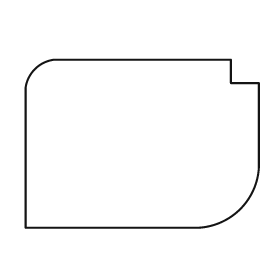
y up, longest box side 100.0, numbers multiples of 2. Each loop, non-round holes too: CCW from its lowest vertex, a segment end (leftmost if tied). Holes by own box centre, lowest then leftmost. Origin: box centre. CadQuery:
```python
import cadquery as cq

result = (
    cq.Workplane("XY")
    .moveTo(-50.0, -36.0)
    .lineTo(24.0, -36.0)
    .threePointArc((42.0, -28.0), (50.0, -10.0))
    .lineTo(50.0, 26.0)
    .lineTo(38.0, 26.0)
    .lineTo(38.0, 36.0)
    .lineTo(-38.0, 36.0)
    .threePointArc((-46.0, 32.0), (-50.0, 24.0))
    .close()
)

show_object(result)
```